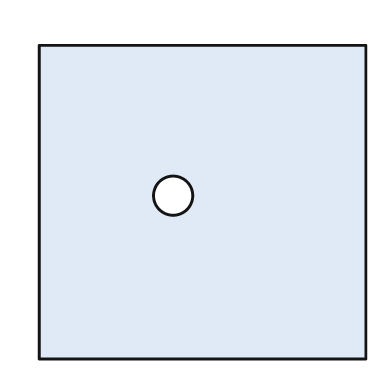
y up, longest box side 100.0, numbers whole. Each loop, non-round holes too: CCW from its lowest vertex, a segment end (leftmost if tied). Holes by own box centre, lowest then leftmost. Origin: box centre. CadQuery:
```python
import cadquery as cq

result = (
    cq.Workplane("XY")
    .moveTo(-50.0, -48.0)
    .lineTo(50.0, -48.0)
    .lineTo(50.0, 48.0)
    .lineTo(-50.0, 48.0)
    .close()
    .moveTo(-9.0, 2.0)
    .circle(6.0)
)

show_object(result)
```